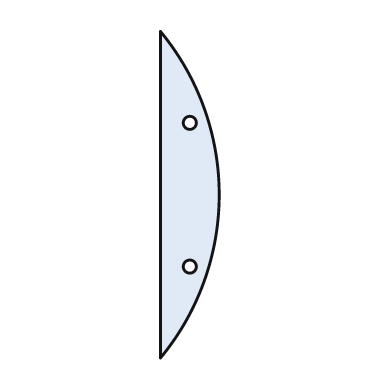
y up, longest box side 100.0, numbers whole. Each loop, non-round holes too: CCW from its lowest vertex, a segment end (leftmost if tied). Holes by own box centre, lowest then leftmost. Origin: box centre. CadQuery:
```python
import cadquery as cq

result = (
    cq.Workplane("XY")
    .moveTo(-9.0, -50.0)
    .threePointArc((9.0, 0.0), (-9.0, 50.0))
    .close()
    .moveTo(0.0, -22.0)
    .circle(2.0)
    .moveTo(0.0, 22.0)
    .circle(2.0)
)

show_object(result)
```